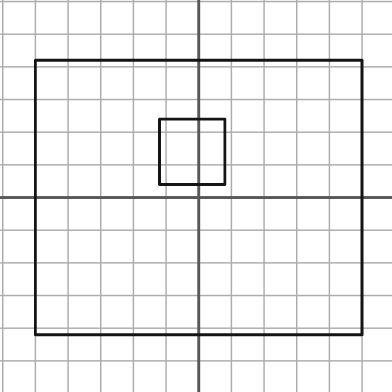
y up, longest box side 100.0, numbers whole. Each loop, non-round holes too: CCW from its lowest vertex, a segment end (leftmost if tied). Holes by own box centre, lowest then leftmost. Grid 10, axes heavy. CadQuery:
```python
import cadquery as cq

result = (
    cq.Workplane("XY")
    .moveTo(-50.0, -42.0)
    .lineTo(50.0, -42.0)
    .lineTo(50.0, 42.0)
    .lineTo(-50.0, 42.0)
    .close()
    .moveTo(-12.0, 4.0)
    .lineTo(8.0, 4.0)
    .lineTo(8.0, 24.0)
    .lineTo(-12.0, 24.0)
    .close()
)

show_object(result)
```